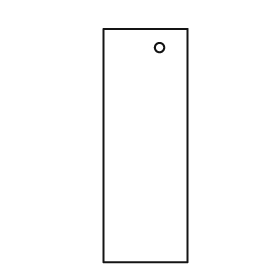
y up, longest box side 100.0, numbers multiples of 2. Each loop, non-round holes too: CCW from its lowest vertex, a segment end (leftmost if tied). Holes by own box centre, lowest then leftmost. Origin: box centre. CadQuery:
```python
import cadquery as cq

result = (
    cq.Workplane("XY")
    .moveTo(-18.0, -50.0)
    .lineTo(18.0, -50.0)
    .lineTo(18.0, 50.0)
    .lineTo(-18.0, 50.0)
    .close()
    .moveTo(6.0, 42.0)
    .circle(2.0)
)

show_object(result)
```